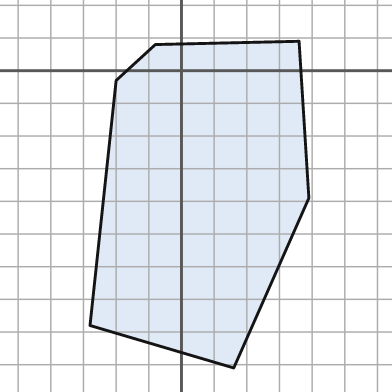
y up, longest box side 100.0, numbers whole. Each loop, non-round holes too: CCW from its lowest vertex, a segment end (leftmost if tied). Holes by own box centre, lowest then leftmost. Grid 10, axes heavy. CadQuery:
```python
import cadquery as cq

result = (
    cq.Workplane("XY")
    .moveTo(16.0, -91.0)
    .lineTo(39.0, -39.0)
    .lineTo(36.0, 9.0)
    .lineTo(-8.0, 8.0)
    .lineTo(-20.0, -3.0)
    .lineTo(-28.0, -78.0)
    .close()
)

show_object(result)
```